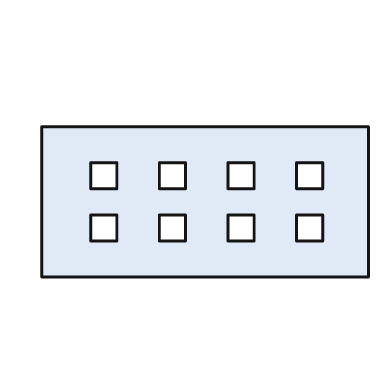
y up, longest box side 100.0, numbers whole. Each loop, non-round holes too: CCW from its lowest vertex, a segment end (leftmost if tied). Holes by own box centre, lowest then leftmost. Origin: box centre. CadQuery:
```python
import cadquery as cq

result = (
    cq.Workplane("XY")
    .moveTo(-50.0, -23.0)
    .lineTo(50.0, -23.0)
    .lineTo(50.0, 23.0)
    .lineTo(-50.0, 23.0)
    .close()
    .moveTo(-35.0, -12.0)
    .lineTo(-27.0, -12.0)
    .lineTo(-27.0, -4.0)
    .lineTo(-35.0, -4.0)
    .close()
    .moveTo(-14.0, -12.0)
    .lineTo(-6.0, -12.0)
    .lineTo(-6.0, -4.0)
    .lineTo(-14.0, -4.0)
    .close()
    .moveTo(7.0, -12.0)
    .lineTo(15.0, -12.0)
    .lineTo(15.0, -4.0)
    .lineTo(7.0, -4.0)
    .close()
    .moveTo(28.0, -12.0)
    .lineTo(36.0, -12.0)
    .lineTo(36.0, -4.0)
    .lineTo(28.0, -4.0)
    .close()
    .moveTo(-35.0, 4.0)
    .lineTo(-27.0, 4.0)
    .lineTo(-27.0, 12.0)
    .lineTo(-35.0, 12.0)
    .close()
    .moveTo(-14.0, 4.0)
    .lineTo(-6.0, 4.0)
    .lineTo(-6.0, 12.0)
    .lineTo(-14.0, 12.0)
    .close()
    .moveTo(7.0, 4.0)
    .lineTo(15.0, 4.0)
    .lineTo(15.0, 12.0)
    .lineTo(7.0, 12.0)
    .close()
    .moveTo(28.0, 4.0)
    .lineTo(36.0, 4.0)
    .lineTo(36.0, 12.0)
    .lineTo(28.0, 12.0)
    .close()
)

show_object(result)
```